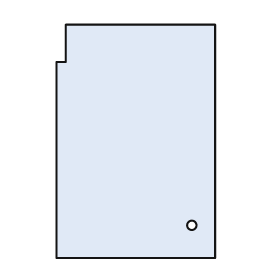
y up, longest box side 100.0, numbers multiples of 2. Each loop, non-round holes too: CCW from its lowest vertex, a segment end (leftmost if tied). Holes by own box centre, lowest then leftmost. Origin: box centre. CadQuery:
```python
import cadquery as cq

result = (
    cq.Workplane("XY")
    .moveTo(-34.0, -50.0)
    .lineTo(34.0, -50.0)
    .lineTo(34.0, 50.0)
    .lineTo(-30.0, 50.0)
    .lineTo(-30.0, 34.0)
    .lineTo(-34.0, 34.0)
    .close()
    .moveTo(24.0, -36.0)
    .circle(2.0)
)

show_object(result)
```